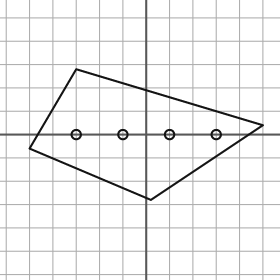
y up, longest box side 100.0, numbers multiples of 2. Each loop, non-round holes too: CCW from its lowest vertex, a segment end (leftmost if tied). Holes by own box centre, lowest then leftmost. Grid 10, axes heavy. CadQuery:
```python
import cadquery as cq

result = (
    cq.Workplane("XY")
    .moveTo(2.0, -28.0)
    .lineTo(50.0, 4.0)
    .lineTo(-30.0, 28.0)
    .lineTo(-50.0, -6.0)
    .close()
    .moveTo(-30.0, 0.0)
    .circle(2.0)
    .moveTo(-10.0, 0.0)
    .circle(2.0)
    .moveTo(10.0, 0.0)
    .circle(2.0)
    .moveTo(30.0, 0.0)
    .circle(2.0)
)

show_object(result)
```